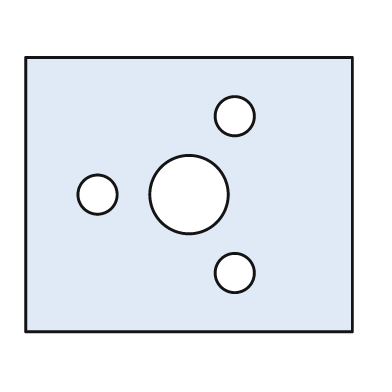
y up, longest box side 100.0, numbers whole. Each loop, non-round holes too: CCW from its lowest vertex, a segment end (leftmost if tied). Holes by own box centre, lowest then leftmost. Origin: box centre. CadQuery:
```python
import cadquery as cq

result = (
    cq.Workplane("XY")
    .moveTo(-50.0, -42.0)
    .lineTo(50.0, -42.0)
    .lineTo(50.0, 42.0)
    .lineTo(-50.0, 42.0)
    .close()
    .moveTo(14.0, -24.0)
    .circle(6.0)
    .moveTo(-28.0, 0.0)
    .circle(6.0)
    .moveTo(0.0, 0.0)
    .circle(12.0)
    .moveTo(14.0, 24.0)
    .circle(6.0)
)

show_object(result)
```